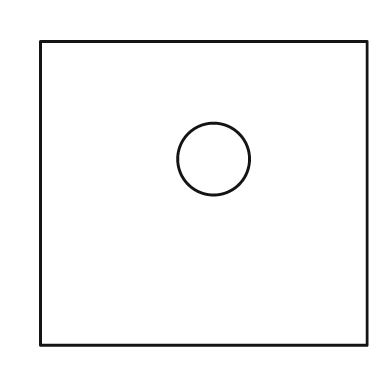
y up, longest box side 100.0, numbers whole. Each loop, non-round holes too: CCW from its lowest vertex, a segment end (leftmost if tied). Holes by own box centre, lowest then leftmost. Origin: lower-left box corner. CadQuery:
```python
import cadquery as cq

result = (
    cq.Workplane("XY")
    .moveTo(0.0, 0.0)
    .lineTo(100.0, 0.0)
    .lineTo(100.0, 93.0)
    .lineTo(0.0, 93.0)
    .close()
    .moveTo(53.0, 57.0)
    .circle(11.0)
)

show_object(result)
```